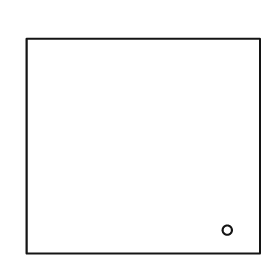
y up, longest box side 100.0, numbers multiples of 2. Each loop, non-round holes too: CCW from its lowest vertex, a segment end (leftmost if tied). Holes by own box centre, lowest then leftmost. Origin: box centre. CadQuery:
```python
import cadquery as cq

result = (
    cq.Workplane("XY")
    .moveTo(-50.0, -46.0)
    .lineTo(50.0, -46.0)
    .lineTo(50.0, 46.0)
    .lineTo(-50.0, 46.0)
    .close()
    .moveTo(36.0, -36.0)
    .circle(2.0)
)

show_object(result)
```